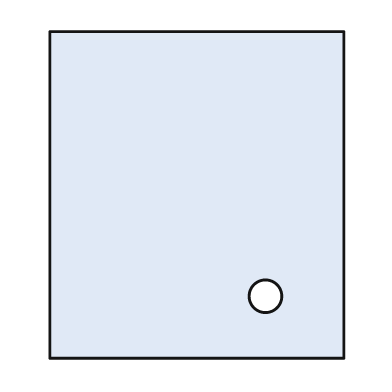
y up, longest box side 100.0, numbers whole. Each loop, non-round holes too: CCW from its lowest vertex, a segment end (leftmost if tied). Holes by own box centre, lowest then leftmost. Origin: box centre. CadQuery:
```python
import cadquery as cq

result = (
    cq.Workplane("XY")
    .moveTo(-45.0, -50.0)
    .lineTo(45.0, -50.0)
    .lineTo(45.0, 50.0)
    .lineTo(-45.0, 50.0)
    .close()
    .moveTo(21.0, -31.0)
    .circle(5.0)
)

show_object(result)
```